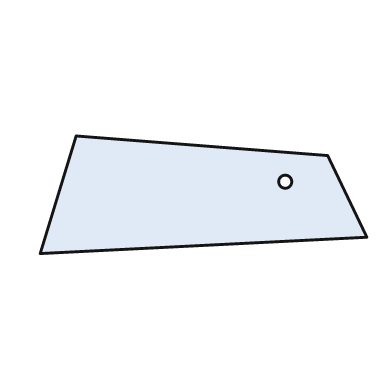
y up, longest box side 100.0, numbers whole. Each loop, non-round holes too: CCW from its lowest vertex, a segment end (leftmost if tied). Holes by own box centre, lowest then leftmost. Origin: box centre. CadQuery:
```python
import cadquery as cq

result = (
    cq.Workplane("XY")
    .moveTo(-50.0, -18.0)
    .lineTo(50.0, -13.0)
    .lineTo(38.0, 12.0)
    .lineTo(-39.0, 18.0)
    .close()
    .moveTo(25.0, 4.0)
    .circle(2.0)
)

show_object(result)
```